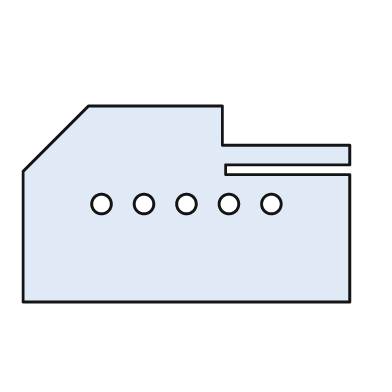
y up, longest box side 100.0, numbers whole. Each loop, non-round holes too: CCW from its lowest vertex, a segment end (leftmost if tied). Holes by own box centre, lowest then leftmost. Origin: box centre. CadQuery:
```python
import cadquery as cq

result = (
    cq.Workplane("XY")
    .moveTo(-50.0, -30.0)
    .lineTo(50.0, -30.0)
    .lineTo(50.0, 9.0)
    .lineTo(12.0, 9.0)
    .lineTo(12.0, 12.0)
    .lineTo(50.0, 12.0)
    .lineTo(50.0, 18.0)
    .lineTo(11.0, 18.0)
    .lineTo(11.0, 30.0)
    .lineTo(-30.0, 30.0)
    .lineTo(-50.0, 10.0)
    .close()
    .moveTo(-26.0, 0.0)
    .circle(3.0)
    .moveTo(-13.0, 0.0)
    .circle(3.0)
    .moveTo(0.0, 0.0)
    .circle(3.0)
    .moveTo(13.0, 0.0)
    .circle(3.0)
    .moveTo(26.0, 0.0)
    .circle(3.0)
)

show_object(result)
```